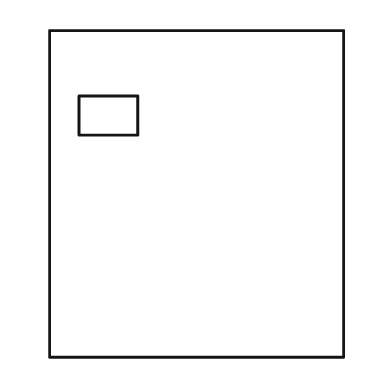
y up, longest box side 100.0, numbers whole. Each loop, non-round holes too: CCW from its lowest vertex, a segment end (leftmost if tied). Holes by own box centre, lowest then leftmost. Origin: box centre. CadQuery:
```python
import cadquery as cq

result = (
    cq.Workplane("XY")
    .moveTo(-45.0, -50.0)
    .lineTo(45.0, -50.0)
    .lineTo(45.0, 50.0)
    .lineTo(-45.0, 50.0)
    .close()
    .moveTo(-36.0, 18.0)
    .lineTo(-18.0, 18.0)
    .lineTo(-18.0, 30.0)
    .lineTo(-36.0, 30.0)
    .close()
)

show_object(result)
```